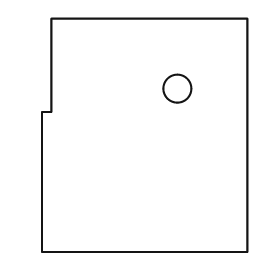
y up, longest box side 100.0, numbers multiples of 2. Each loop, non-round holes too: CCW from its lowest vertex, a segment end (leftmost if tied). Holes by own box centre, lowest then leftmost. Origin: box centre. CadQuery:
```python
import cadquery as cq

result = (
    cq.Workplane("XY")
    .moveTo(-44.0, -50.0)
    .lineTo(44.0, -50.0)
    .lineTo(44.0, 50.0)
    .lineTo(-40.0, 50.0)
    .lineTo(-40.0, 10.0)
    .lineTo(-44.0, 10.0)
    .close()
    .moveTo(14.0, 20.0)
    .circle(6.0)
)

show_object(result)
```